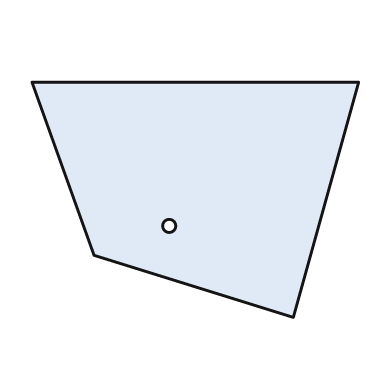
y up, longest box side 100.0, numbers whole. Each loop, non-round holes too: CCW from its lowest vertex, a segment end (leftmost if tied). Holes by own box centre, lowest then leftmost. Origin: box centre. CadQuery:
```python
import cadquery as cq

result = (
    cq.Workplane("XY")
    .moveTo(30.0, -36.0)
    .lineTo(50.0, 36.0)
    .lineTo(-50.0, 36.0)
    .lineTo(-31.0, -17.0)
    .close()
    .moveTo(-8.0, -8.0)
    .circle(2.0)
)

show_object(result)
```